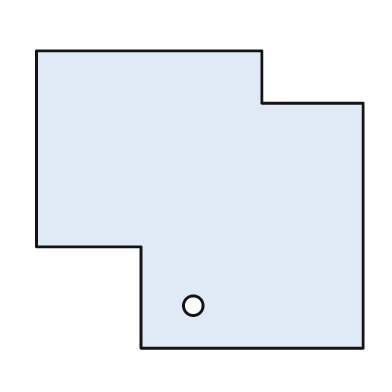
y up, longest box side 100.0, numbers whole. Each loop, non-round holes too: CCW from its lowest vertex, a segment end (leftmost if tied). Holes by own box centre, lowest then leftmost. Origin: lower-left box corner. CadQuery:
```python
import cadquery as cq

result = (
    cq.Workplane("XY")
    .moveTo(32.0, 0.0)
    .lineTo(100.0, 0.0)
    .lineTo(100.0, 75.0)
    .lineTo(69.0, 75.0)
    .lineTo(69.0, 91.0)
    .lineTo(0.0, 91.0)
    .lineTo(0.0, 31.0)
    .lineTo(32.0, 31.0)
    .close()
    .moveTo(48.0, 13.0)
    .circle(3.0)
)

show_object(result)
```